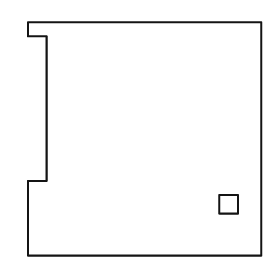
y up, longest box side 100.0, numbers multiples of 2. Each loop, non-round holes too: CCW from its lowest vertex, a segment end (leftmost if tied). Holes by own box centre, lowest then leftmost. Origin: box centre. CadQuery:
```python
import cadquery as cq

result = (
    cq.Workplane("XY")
    .moveTo(-50.0, -50.0)
    .lineTo(50.0, -50.0)
    .lineTo(50.0, 50.0)
    .lineTo(-50.0, 50.0)
    .lineTo(-50.0, 44.0)
    .lineTo(-42.0, 44.0)
    .lineTo(-42.0, -18.0)
    .lineTo(-50.0, -18.0)
    .close()
    .moveTo(32.0, -32.0)
    .lineTo(40.0, -32.0)
    .lineTo(40.0, -24.0)
    .lineTo(32.0, -24.0)
    .close()
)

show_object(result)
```